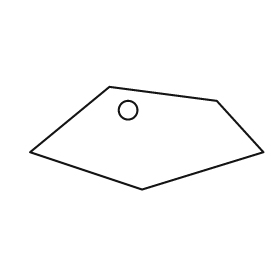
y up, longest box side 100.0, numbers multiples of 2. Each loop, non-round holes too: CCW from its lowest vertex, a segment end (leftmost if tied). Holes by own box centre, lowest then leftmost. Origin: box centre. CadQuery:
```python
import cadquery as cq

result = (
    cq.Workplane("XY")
    .moveTo(-2.0, -22.0)
    .lineTo(50.0, -6.0)
    .lineTo(30.0, 16.0)
    .lineTo(-16.0, 22.0)
    .lineTo(-50.0, -6.0)
    .close()
    .moveTo(-8.0, 12.0)
    .circle(4.0)
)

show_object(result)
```